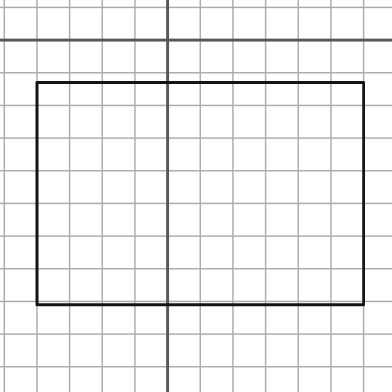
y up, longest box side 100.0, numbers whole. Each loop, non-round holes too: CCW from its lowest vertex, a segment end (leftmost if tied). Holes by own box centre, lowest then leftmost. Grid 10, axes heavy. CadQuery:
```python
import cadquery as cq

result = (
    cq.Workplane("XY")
    .moveTo(-40.0, -81.0)
    .lineTo(60.0, -81.0)
    .lineTo(60.0, -13.0)
    .lineTo(-40.0, -13.0)
    .close()
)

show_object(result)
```